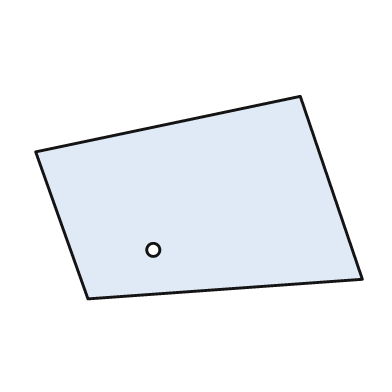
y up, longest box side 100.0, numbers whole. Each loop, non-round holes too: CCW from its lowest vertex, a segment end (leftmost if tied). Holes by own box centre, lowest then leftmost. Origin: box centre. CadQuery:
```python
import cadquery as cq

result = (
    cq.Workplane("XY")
    .moveTo(-34.0, -31.0)
    .lineTo(50.0, -25.0)
    .lineTo(31.0, 31.0)
    .lineTo(-50.0, 14.0)
    .close()
    .moveTo(-14.0, -16.0)
    .circle(2.0)
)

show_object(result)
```